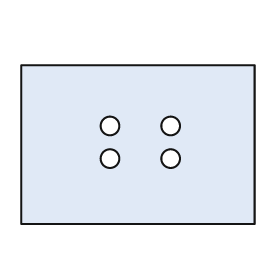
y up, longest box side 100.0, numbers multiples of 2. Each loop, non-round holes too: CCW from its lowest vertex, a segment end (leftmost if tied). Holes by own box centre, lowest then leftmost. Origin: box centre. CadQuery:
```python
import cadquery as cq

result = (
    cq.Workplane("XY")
    .moveTo(-50.0, -34.0)
    .lineTo(50.0, -34.0)
    .lineTo(50.0, 34.0)
    .lineTo(-50.0, 34.0)
    .close()
    .moveTo(-12.0, -6.0)
    .circle(4.0)
    .moveTo(14.0, -6.0)
    .circle(4.0)
    .moveTo(-12.0, 8.0)
    .circle(4.0)
    .moveTo(14.0, 8.0)
    .circle(4.0)
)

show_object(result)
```